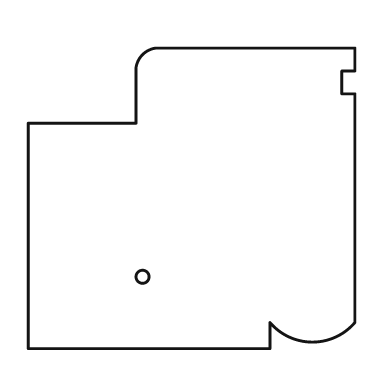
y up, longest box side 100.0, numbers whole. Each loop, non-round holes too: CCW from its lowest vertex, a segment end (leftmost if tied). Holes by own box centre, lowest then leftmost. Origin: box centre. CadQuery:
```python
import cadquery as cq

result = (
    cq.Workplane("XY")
    .moveTo(-50.0, -46.0)
    .lineTo(24.0, -46.0)
    .lineTo(24.0, -38.0)
    .threePointArc((37.0, -44.0), (50.0, -38.0))
    .lineTo(50.0, 32.0)
    .lineTo(46.0, 32.0)
    .lineTo(46.0, 39.0)
    .lineTo(50.0, 39.0)
    .lineTo(50.0, 46.0)
    .lineTo(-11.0, 46.0)
    .threePointArc((-15.0, 44.0), (-17.0, 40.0))
    .lineTo(-17.0, 23.0)
    .lineTo(-50.0, 23.0)
    .close()
    .moveTo(-15.0, -24.0)
    .circle(2.0)
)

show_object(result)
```